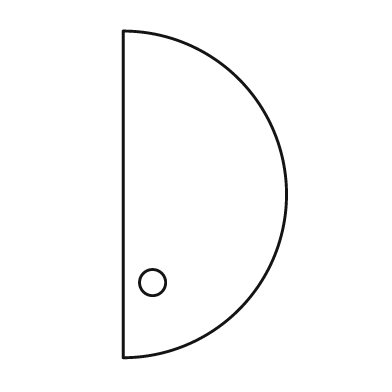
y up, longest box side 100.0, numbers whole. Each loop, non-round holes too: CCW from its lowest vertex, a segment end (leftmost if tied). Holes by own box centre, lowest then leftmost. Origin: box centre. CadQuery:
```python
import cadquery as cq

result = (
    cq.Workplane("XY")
    .moveTo(-25.0, -50.0)
    .threePointArc((25.0, 0.0), (-25.0, 50.0))
    .close()
    .moveTo(-16.0, -27.0)
    .circle(4.0)
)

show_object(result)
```